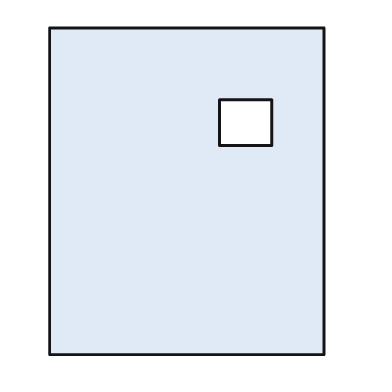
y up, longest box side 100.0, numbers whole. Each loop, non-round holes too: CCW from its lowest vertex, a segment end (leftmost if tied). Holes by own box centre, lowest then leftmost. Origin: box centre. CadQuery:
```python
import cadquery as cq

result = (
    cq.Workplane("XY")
    .moveTo(-42.0, -50.0)
    .lineTo(42.0, -50.0)
    .lineTo(42.0, 50.0)
    .lineTo(-42.0, 50.0)
    .close()
    .moveTo(10.0, 14.0)
    .lineTo(26.0, 14.0)
    .lineTo(26.0, 28.0)
    .lineTo(10.0, 28.0)
    .close()
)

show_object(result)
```